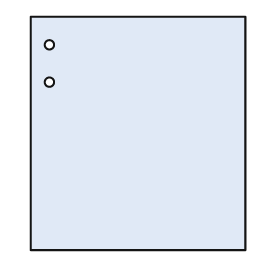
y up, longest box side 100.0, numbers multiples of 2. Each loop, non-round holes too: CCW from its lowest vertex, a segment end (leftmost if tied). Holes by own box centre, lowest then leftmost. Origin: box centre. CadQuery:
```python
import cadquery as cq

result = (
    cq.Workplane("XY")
    .moveTo(-46.0, -50.0)
    .lineTo(46.0, -50.0)
    .lineTo(46.0, 50.0)
    .lineTo(-46.0, 50.0)
    .close()
    .moveTo(-38.0, 22.0)
    .circle(2.0)
    .moveTo(-38.0, 38.0)
    .circle(2.0)
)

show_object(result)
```